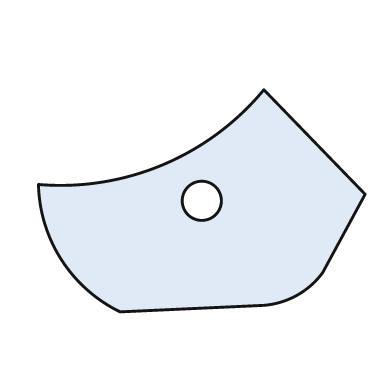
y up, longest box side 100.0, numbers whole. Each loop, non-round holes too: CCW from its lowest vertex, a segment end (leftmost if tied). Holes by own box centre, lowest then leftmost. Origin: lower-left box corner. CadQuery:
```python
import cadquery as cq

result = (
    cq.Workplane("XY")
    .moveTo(25.0, 0.0)
    .lineTo(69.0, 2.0)
    .threePointArc((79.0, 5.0), (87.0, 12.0))
    .lineTo(100.0, 36.0)
    .lineTo(69.0, 68.0)
    .threePointArc((38.0, 45.0), (0.0, 39.0))
    .threePointArc((7.0, 16.0), (25.0, 0.0))
    .close()
    .moveTo(50.0, 34.0)
    .circle(6.0)
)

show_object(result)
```